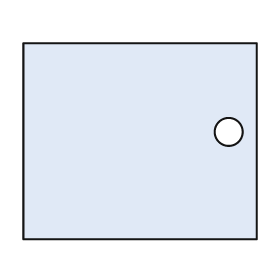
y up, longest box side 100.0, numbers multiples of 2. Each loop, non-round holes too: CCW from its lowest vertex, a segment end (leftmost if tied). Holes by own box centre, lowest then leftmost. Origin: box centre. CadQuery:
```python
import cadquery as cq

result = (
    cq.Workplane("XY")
    .moveTo(-50.0, -42.0)
    .lineTo(50.0, -42.0)
    .lineTo(50.0, 42.0)
    .lineTo(-50.0, 42.0)
    .close()
    .moveTo(38.0, 4.0)
    .circle(6.0)
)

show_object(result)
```